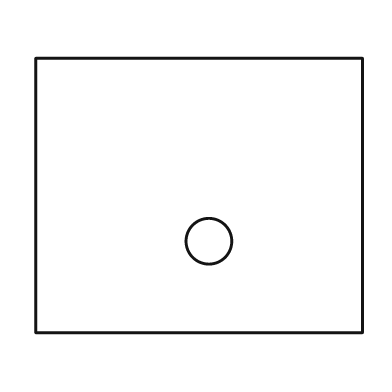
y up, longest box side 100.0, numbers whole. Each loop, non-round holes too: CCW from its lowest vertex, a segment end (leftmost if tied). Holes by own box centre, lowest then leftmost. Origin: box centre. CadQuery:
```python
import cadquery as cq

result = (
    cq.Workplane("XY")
    .moveTo(-50.0, -42.0)
    .lineTo(50.0, -42.0)
    .lineTo(50.0, 42.0)
    .lineTo(-50.0, 42.0)
    .close()
    .moveTo(3.0, -14.0)
    .circle(7.0)
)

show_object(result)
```